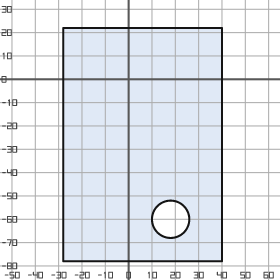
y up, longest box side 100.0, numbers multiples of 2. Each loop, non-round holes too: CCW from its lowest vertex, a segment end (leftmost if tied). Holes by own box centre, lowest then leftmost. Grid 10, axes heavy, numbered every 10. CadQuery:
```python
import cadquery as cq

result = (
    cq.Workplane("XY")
    .moveTo(-28.0, -78.0)
    .lineTo(40.0, -78.0)
    .lineTo(40.0, 22.0)
    .lineTo(-28.0, 22.0)
    .close()
    .moveTo(18.0, -60.0)
    .circle(8.0)
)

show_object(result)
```